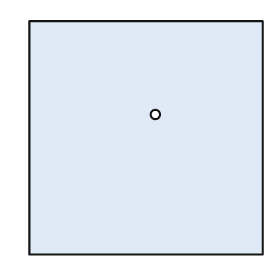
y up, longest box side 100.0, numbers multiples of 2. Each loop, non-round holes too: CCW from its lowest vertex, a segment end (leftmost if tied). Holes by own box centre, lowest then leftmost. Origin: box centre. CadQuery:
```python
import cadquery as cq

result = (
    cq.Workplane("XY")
    .moveTo(-50.0, -50.0)
    .lineTo(50.0, -50.0)
    .lineTo(50.0, 50.0)
    .lineTo(-50.0, 50.0)
    .close()
    .moveTo(4.0, 10.0)
    .circle(2.0)
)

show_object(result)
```